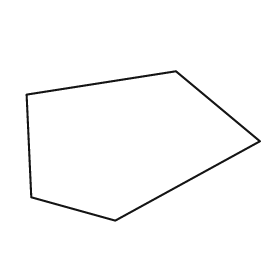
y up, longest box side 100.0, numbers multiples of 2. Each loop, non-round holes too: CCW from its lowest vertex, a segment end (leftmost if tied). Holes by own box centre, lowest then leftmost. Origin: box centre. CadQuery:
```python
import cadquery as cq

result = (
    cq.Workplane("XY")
    .moveTo(-12.0, -32.0)
    .lineTo(50.0, 2.0)
    .lineTo(14.0, 32.0)
    .lineTo(-50.0, 22.0)
    .lineTo(-48.0, -22.0)
    .close()
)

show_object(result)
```